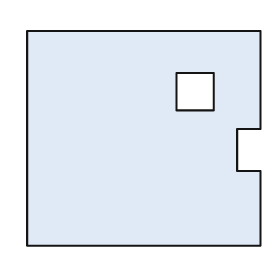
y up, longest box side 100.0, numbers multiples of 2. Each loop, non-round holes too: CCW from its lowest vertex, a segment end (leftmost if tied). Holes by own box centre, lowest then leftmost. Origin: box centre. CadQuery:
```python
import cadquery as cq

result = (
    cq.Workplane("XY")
    .moveTo(-50.0, -46.0)
    .lineTo(50.0, -46.0)
    .lineTo(50.0, -14.0)
    .lineTo(40.0, -14.0)
    .lineTo(40.0, 4.0)
    .lineTo(50.0, 4.0)
    .lineTo(50.0, 46.0)
    .lineTo(-50.0, 46.0)
    .close()
    .moveTo(14.0, 12.0)
    .lineTo(30.0, 12.0)
    .lineTo(30.0, 28.0)
    .lineTo(14.0, 28.0)
    .close()
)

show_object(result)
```